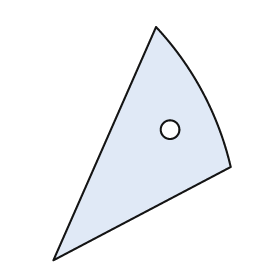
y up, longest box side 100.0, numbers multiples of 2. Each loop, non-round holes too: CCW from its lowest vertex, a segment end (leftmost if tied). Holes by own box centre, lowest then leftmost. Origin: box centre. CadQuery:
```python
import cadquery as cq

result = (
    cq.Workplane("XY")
    .moveTo(-38.0, -50.0)
    .lineTo(38.0, -10.0)
    .threePointArc((26.0, 22.0), (6.0, 50.0))
    .close()
    .moveTo(12.0, 6.0)
    .circle(4.0)
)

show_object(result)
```